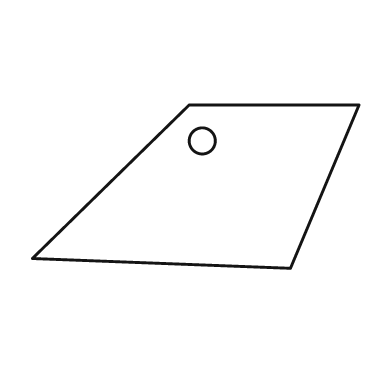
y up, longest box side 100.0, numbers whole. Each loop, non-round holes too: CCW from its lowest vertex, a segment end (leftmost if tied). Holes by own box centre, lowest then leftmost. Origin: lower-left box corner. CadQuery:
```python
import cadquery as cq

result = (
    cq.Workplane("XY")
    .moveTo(79.0, 0.0)
    .lineTo(100.0, 50.0)
    .lineTo(48.0, 50.0)
    .lineTo(0.0, 3.0)
    .close()
    .moveTo(52.0, 39.0)
    .circle(4.0)
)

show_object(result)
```